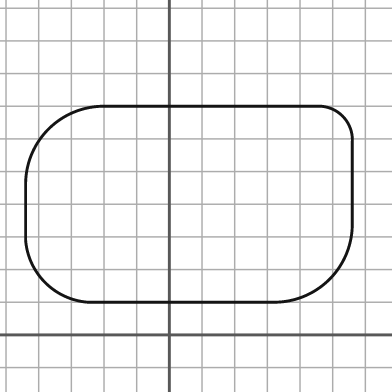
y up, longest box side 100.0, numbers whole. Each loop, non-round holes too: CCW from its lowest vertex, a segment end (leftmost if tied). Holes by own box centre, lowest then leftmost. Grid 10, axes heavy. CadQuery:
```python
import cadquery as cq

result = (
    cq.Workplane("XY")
    .moveTo(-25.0, 10.0)
    .lineTo(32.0, 10.0)
    .threePointArc((49.0, 17.0), (56.0, 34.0))
    .lineTo(56.0, 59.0)
    .threePointArc((53.0, 67.0), (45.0, 70.0))
    .lineTo(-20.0, 70.0)
    .threePointArc((-37.0, 63.0), (-44.0, 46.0))
    .lineTo(-44.0, 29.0)
    .threePointArc((-38.0, 16.0), (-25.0, 10.0))
    .close()
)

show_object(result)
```